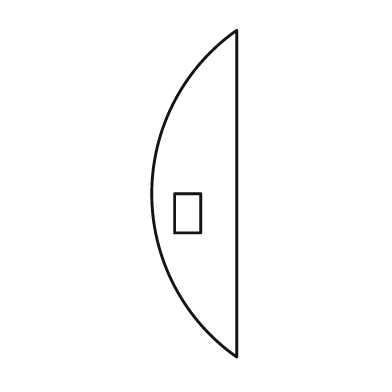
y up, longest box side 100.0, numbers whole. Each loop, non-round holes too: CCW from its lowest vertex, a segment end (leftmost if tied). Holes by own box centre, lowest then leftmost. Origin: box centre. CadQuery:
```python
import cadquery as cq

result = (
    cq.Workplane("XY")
    .moveTo(13.0, -50.0)
    .lineTo(13.0, 50.0)
    .threePointArc((-13.0, 0.0), (13.0, -50.0))
    .close()
    .moveTo(-6.0, -12.0)
    .lineTo(2.0, -12.0)
    .lineTo(2.0, 0.0)
    .lineTo(-6.0, 0.0)
    .close()
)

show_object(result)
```